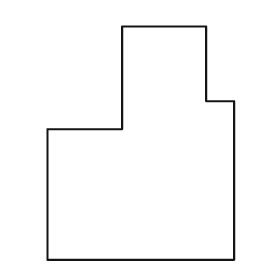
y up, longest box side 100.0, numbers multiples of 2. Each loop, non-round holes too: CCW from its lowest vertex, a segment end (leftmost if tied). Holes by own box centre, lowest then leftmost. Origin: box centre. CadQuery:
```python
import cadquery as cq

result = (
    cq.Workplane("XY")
    .moveTo(-40.0, -50.0)
    .lineTo(40.0, -50.0)
    .lineTo(40.0, 18.0)
    .lineTo(28.0, 18.0)
    .lineTo(28.0, 50.0)
    .lineTo(-8.0, 50.0)
    .lineTo(-8.0, 6.0)
    .lineTo(-40.0, 6.0)
    .close()
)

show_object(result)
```